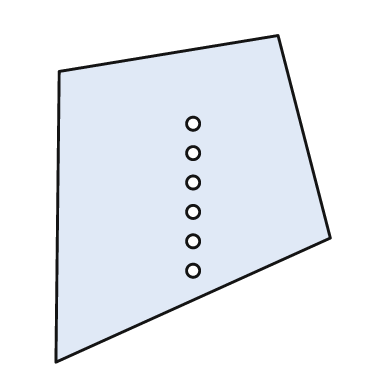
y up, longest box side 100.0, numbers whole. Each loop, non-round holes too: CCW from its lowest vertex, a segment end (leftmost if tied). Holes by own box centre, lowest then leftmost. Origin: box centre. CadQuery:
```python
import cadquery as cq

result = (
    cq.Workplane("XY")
    .moveTo(-42.0, -50.0)
    .lineTo(42.0, -12.0)
    .lineTo(26.0, 50.0)
    .lineTo(-41.0, 39.0)
    .close()
    .moveTo(0.0, -22.0)
    .circle(2.0)
    .moveTo(0.0, -13.0)
    .circle(2.0)
    .moveTo(0.0, -4.0)
    .circle(2.0)
    .moveTo(0.0, 5.0)
    .circle(2.0)
    .moveTo(0.0, 14.0)
    .circle(2.0)
    .moveTo(0.0, 23.0)
    .circle(2.0)
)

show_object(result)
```